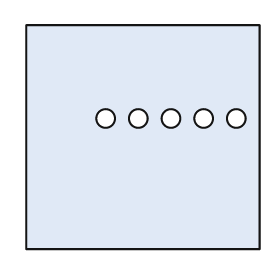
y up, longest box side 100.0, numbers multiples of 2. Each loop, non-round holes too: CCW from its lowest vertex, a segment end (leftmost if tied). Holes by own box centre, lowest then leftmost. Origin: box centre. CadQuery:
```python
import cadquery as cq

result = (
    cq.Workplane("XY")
    .moveTo(-50.0, -48.0)
    .lineTo(50.0, -48.0)
    .lineTo(50.0, 48.0)
    .lineTo(-50.0, 48.0)
    .close()
    .moveTo(-16.0, 8.0)
    .circle(4.0)
    .moveTo(-2.0, 8.0)
    .circle(4.0)
    .moveTo(12.0, 8.0)
    .circle(4.0)
    .moveTo(26.0, 8.0)
    .circle(4.0)
    .moveTo(40.0, 8.0)
    .circle(4.0)
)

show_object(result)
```